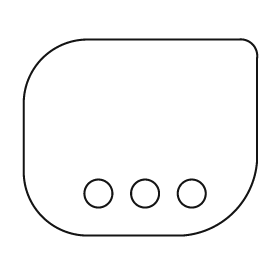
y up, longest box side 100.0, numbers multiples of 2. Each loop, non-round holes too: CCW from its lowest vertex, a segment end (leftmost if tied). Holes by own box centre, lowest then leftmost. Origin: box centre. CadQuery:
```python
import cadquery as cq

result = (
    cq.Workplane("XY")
    .moveTo(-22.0, -42.0)
    .lineTo(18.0, -42.0)
    .threePointArc((40.0, -32.0), (50.0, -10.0))
    .lineTo(50.0, 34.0)
    .threePointArc((48.0, 40.0), (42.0, 42.0))
    .lineTo(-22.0, 42.0)
    .threePointArc((-42.0, 34.0), (-50.0, 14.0))
    .lineTo(-50.0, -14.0)
    .threePointArc((-42.0, -34.0), (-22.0, -42.0))
    .close()
    .moveTo(-18.0, -24.0)
    .circle(6.0)
    .moveTo(2.0, -24.0)
    .circle(6.0)
    .moveTo(22.0, -24.0)
    .circle(6.0)
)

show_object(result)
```